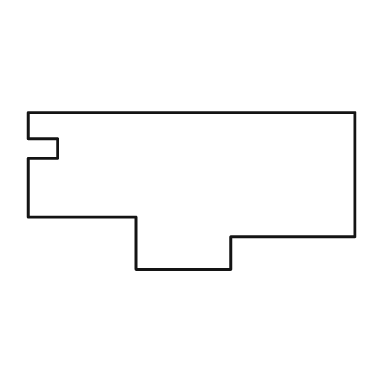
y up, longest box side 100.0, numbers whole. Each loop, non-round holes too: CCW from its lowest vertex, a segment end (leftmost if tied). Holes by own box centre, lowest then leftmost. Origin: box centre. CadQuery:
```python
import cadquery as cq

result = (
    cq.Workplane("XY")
    .moveTo(-17.0, -24.0)
    .lineTo(12.0, -24.0)
    .lineTo(12.0, -14.0)
    .lineTo(50.0, -14.0)
    .lineTo(50.0, 24.0)
    .lineTo(-50.0, 24.0)
    .lineTo(-50.0, 16.0)
    .lineTo(-41.0, 16.0)
    .lineTo(-41.0, 10.0)
    .lineTo(-50.0, 10.0)
    .lineTo(-50.0, -8.0)
    .lineTo(-17.0, -8.0)
    .close()
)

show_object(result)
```